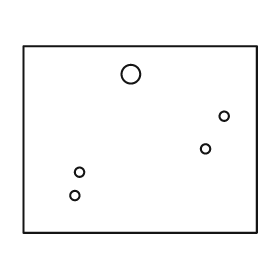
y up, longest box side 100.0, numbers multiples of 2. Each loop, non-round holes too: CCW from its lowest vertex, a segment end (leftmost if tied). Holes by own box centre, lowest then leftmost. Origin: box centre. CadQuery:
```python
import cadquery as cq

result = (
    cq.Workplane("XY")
    .moveTo(-50.0, -40.0)
    .lineTo(50.0, -40.0)
    .lineTo(50.0, 40.0)
    .lineTo(-50.0, 40.0)
    .close()
    .moveTo(-28.0, -24.0)
    .circle(2.0)
    .moveTo(-26.0, -14.0)
    .circle(2.0)
    .moveTo(28.0, -4.0)
    .circle(2.0)
    .moveTo(36.0, 10.0)
    .circle(2.0)
    .moveTo(-4.0, 28.0)
    .circle(4.0)
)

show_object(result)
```